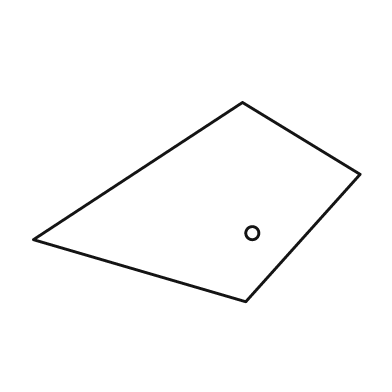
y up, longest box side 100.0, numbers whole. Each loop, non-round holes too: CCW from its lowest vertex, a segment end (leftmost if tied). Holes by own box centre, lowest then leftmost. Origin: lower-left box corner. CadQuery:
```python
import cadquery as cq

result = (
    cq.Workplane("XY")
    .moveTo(65.0, 0.0)
    .lineTo(100.0, 39.0)
    .lineTo(64.0, 61.0)
    .lineTo(0.0, 19.0)
    .close()
    .moveTo(67.0, 21.0)
    .circle(2.0)
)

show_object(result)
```